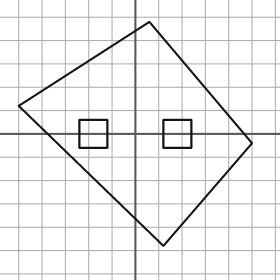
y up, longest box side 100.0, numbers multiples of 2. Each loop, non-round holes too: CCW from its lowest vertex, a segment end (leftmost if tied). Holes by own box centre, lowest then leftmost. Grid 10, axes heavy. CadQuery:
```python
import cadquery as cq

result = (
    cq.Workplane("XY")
    .moveTo(12.0, -48.0)
    .lineTo(50.0, -4.0)
    .lineTo(6.0, 48.0)
    .lineTo(-50.0, 12.0)
    .close()
    .moveTo(-24.0, -6.0)
    .lineTo(-12.0, -6.0)
    .lineTo(-12.0, 6.0)
    .lineTo(-24.0, 6.0)
    .close()
    .moveTo(12.0, -6.0)
    .lineTo(24.0, -6.0)
    .lineTo(24.0, 6.0)
    .lineTo(12.0, 6.0)
    .close()
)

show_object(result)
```